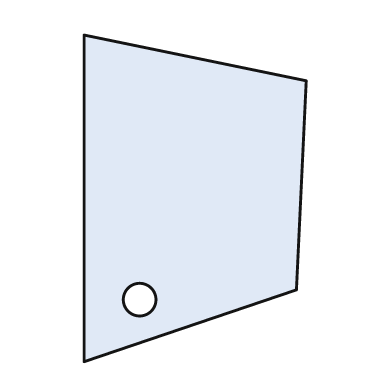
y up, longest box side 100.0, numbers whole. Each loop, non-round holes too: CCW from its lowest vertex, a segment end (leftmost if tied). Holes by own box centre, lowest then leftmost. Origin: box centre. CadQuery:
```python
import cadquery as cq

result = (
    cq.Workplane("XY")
    .moveTo(-34.0, -50.0)
    .lineTo(31.0, -28.0)
    .lineTo(34.0, 36.0)
    .lineTo(-34.0, 50.0)
    .close()
    .moveTo(-17.0, -31.0)
    .circle(5.0)
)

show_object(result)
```